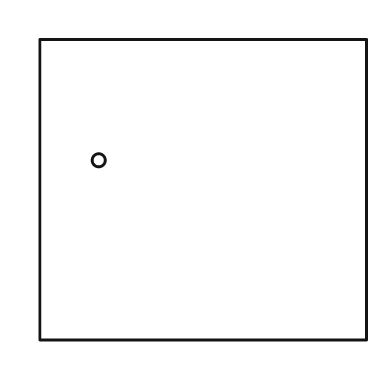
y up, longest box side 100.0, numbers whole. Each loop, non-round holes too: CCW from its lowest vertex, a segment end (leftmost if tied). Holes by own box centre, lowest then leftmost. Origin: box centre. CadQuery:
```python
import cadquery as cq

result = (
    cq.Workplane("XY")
    .moveTo(-50.0, -46.0)
    .lineTo(50.0, -46.0)
    .lineTo(50.0, 46.0)
    .lineTo(-50.0, 46.0)
    .close()
    .moveTo(-32.0, 9.0)
    .circle(2.0)
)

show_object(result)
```